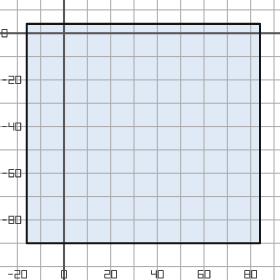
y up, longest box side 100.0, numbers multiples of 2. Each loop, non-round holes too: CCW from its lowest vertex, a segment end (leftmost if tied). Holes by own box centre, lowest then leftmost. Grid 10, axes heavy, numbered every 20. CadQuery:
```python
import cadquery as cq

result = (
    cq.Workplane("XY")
    .moveTo(-16.0, -90.0)
    .lineTo(84.0, -90.0)
    .lineTo(84.0, 4.0)
    .lineTo(-16.0, 4.0)
    .close()
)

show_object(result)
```